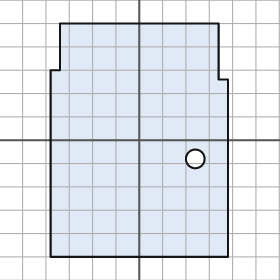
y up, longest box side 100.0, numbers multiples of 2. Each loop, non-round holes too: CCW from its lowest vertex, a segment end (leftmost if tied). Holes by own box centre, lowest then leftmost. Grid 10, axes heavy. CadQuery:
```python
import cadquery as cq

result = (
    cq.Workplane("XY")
    .moveTo(-38.0, -50.0)
    .lineTo(38.0, -50.0)
    .lineTo(38.0, 26.0)
    .lineTo(34.0, 26.0)
    .lineTo(34.0, 50.0)
    .lineTo(-34.0, 50.0)
    .lineTo(-34.0, 30.0)
    .lineTo(-38.0, 30.0)
    .close()
    .moveTo(24.0, -8.0)
    .circle(4.0)
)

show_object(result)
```